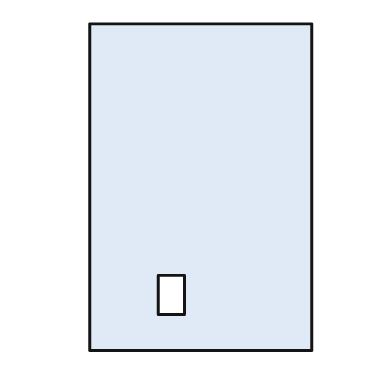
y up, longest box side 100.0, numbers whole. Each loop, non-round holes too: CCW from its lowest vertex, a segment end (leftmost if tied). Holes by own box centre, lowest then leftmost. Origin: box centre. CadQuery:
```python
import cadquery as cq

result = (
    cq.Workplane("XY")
    .moveTo(-34.0, -50.0)
    .lineTo(34.0, -50.0)
    .lineTo(34.0, 50.0)
    .lineTo(-34.0, 50.0)
    .close()
    .moveTo(-13.0, -39.0)
    .lineTo(-5.0, -39.0)
    .lineTo(-5.0, -27.0)
    .lineTo(-13.0, -27.0)
    .close()
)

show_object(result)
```